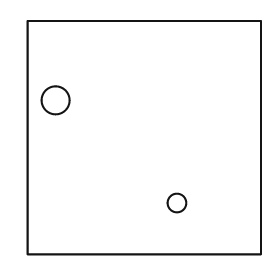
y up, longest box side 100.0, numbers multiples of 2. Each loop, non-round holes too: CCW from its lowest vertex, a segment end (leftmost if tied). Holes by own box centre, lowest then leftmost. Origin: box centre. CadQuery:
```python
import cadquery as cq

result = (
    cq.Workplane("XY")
    .moveTo(-50.0, -50.0)
    .lineTo(50.0, -50.0)
    .lineTo(50.0, 50.0)
    .lineTo(-50.0, 50.0)
    .close()
    .moveTo(14.0, -28.0)
    .circle(4.0)
    .moveTo(-38.0, 16.0)
    .circle(6.0)
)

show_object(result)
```